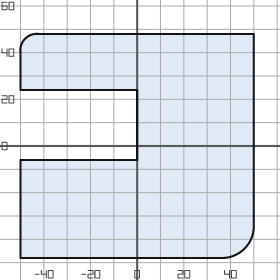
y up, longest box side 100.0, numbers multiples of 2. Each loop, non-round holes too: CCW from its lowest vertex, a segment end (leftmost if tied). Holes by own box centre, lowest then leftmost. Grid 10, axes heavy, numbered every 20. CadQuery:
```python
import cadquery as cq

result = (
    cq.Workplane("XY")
    .moveTo(-50.0, -48.0)
    .lineTo(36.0, -48.0)
    .threePointArc((46.0, -44.0), (50.0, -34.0))
    .lineTo(50.0, 48.0)
    .lineTo(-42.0, 48.0)
    .threePointArc((-48.0, 46.0), (-50.0, 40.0))
    .lineTo(-50.0, 24.0)
    .lineTo(0.0, 24.0)
    .lineTo(0.0, -6.0)
    .lineTo(-50.0, -6.0)
    .close()
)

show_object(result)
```